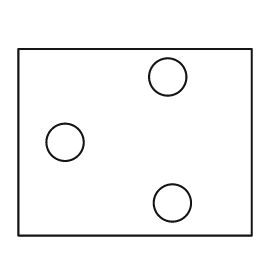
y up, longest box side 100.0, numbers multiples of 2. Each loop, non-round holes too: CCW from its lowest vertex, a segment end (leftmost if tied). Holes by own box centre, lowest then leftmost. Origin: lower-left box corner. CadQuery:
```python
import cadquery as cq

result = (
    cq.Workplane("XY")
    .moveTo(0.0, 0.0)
    .lineTo(100.0, 0.0)
    .lineTo(100.0, 80.0)
    .lineTo(0.0, 80.0)
    .close()
    .moveTo(66.0, 14.0)
    .circle(8.0)
    .moveTo(20.0, 40.0)
    .circle(8.0)
    .moveTo(64.0, 68.0)
    .circle(8.0)
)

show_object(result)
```